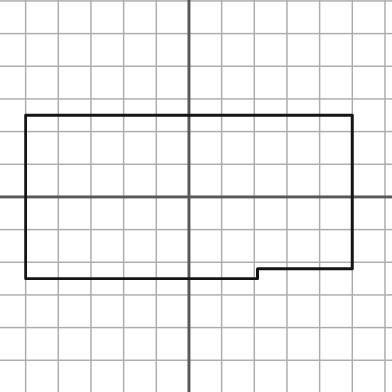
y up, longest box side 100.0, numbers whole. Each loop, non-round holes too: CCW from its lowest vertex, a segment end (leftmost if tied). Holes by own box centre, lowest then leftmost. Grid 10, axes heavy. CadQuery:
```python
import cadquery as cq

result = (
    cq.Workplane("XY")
    .moveTo(-50.0, -25.0)
    .lineTo(21.0, -25.0)
    .lineTo(21.0, -22.0)
    .lineTo(50.0, -22.0)
    .lineTo(50.0, 25.0)
    .lineTo(-50.0, 25.0)
    .close()
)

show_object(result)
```